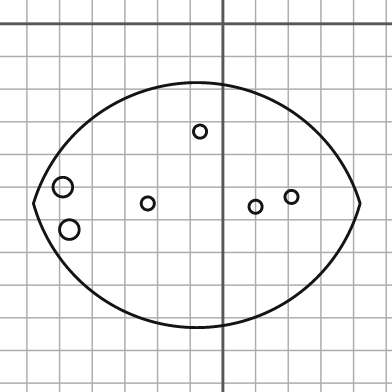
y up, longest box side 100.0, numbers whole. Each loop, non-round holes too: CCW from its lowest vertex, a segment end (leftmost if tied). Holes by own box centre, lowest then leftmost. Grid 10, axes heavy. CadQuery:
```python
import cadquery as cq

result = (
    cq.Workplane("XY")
    .moveTo(-58.0, -55.0)
    .threePointArc((-8.0, -93.0), (42.0, -55.0))
    .threePointArc((-8.0, -18.0), (-58.0, -55.0))
    .close()
    .moveTo(-47.0, -63.0)
    .circle(3.0)
    .moveTo(10.0, -56.0)
    .circle(2.0)
    .moveTo(-23.0, -55.0)
    .circle(2.0)
    .moveTo(21.0, -53.0)
    .circle(2.0)
    .moveTo(-49.0, -50.0)
    .circle(3.0)
    .moveTo(-7.0, -33.0)
    .circle(2.0)
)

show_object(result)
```